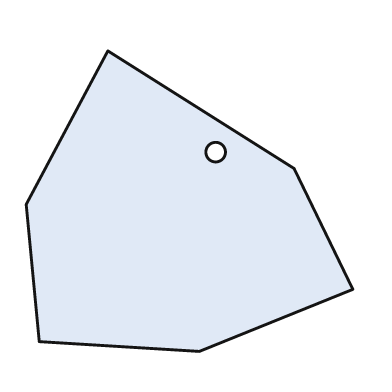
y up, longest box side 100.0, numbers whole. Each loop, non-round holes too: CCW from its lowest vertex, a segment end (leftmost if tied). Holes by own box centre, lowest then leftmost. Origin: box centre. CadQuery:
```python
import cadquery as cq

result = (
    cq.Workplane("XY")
    .moveTo(3.0, -46.0)
    .lineTo(50.0, -27.0)
    .lineTo(32.0, 10.0)
    .lineTo(-25.0, 46.0)
    .lineTo(-50.0, -1.0)
    .lineTo(-46.0, -43.0)
    .close()
    .moveTo(8.0, 15.0)
    .circle(3.0)
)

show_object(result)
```